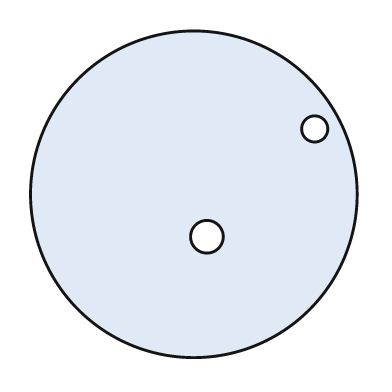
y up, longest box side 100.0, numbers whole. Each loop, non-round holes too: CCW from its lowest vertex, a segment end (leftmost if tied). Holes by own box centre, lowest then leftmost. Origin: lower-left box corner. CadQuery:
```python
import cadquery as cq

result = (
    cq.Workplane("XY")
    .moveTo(50.0, 50.0)
    .circle(50.0)
    .moveTo(54.0, 37.0)
    .circle(5.0)
    .moveTo(87.0, 70.0)
    .circle(4.0)
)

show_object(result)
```